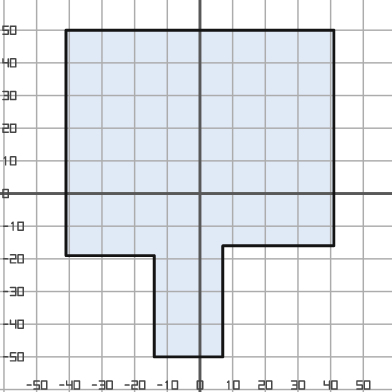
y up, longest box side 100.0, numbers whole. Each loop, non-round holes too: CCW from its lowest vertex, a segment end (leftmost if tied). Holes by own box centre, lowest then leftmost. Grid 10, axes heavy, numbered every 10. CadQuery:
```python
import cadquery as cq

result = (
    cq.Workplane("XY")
    .moveTo(-14.0, -50.0)
    .lineTo(7.0, -50.0)
    .lineTo(7.0, -16.0)
    .lineTo(41.0, -16.0)
    .lineTo(41.0, 50.0)
    .lineTo(-41.0, 50.0)
    .lineTo(-41.0, -19.0)
    .lineTo(-14.0, -19.0)
    .close()
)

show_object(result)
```